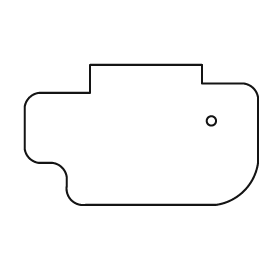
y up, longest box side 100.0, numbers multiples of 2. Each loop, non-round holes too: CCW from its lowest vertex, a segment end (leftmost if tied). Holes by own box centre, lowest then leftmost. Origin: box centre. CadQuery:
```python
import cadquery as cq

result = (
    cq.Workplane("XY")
    .moveTo(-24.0, -30.0)
    .lineTo(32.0, -30.0)
    .threePointArc((44.0, -24.0), (50.0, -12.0))
    .lineTo(50.0, 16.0)
    .threePointArc((48.0, 20.0), (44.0, 22.0))
    .lineTo(26.0, 22.0)
    .lineTo(26.0, 30.0)
    .lineTo(-22.0, 30.0)
    .lineTo(-22.0, 18.0)
    .lineTo(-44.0, 18.0)
    .threePointArc((-48.0, 16.0), (-50.0, 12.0))
    .lineTo(-50.0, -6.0)
    .threePointArc((-48.0, -10.0), (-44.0, -12.0))
    .lineTo(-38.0, -12.0)
    .threePointArc((-34.0, -14.0), (-32.0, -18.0))
    .lineTo(-32.0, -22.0)
    .threePointArc((-30.0, -28.0), (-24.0, -30.0))
    .close()
    .moveTo(30.0, 6.0)
    .circle(2.0)
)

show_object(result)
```